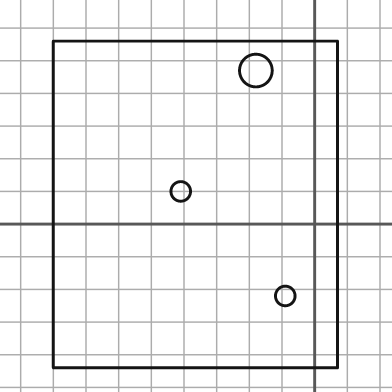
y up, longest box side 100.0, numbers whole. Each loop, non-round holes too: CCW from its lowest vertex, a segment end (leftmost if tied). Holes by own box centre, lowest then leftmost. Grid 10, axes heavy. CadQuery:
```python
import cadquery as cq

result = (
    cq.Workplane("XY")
    .moveTo(-80.0, -44.0)
    .lineTo(7.0, -44.0)
    .lineTo(7.0, 56.0)
    .lineTo(-80.0, 56.0)
    .close()
    .moveTo(-9.0, -22.0)
    .circle(3.0)
    .moveTo(-41.0, 10.0)
    .circle(3.0)
    .moveTo(-18.0, 47.0)
    .circle(5.0)
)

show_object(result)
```